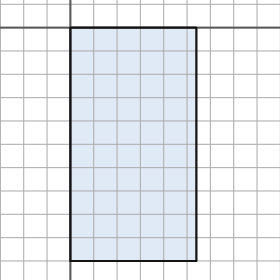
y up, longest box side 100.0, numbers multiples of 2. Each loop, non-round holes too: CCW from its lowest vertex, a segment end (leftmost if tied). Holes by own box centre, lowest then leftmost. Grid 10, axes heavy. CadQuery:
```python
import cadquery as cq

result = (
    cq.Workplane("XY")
    .moveTo(0.0, -100.0)
    .lineTo(54.0, -100.0)
    .lineTo(54.0, 0.0)
    .lineTo(0.0, 0.0)
    .close()
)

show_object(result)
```